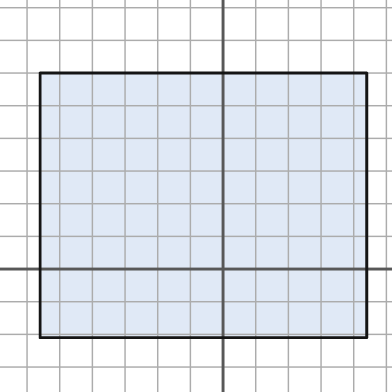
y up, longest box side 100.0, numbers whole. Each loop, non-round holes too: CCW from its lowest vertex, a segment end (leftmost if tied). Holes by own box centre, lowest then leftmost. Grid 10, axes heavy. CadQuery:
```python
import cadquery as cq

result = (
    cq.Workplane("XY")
    .moveTo(-56.0, -21.0)
    .lineTo(44.0, -21.0)
    .lineTo(44.0, 60.0)
    .lineTo(-56.0, 60.0)
    .close()
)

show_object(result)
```